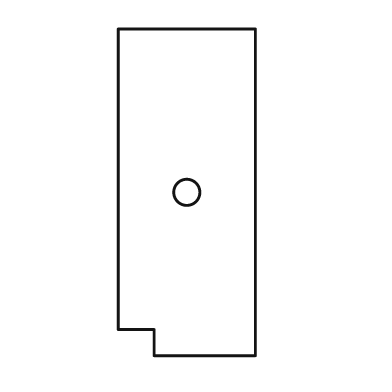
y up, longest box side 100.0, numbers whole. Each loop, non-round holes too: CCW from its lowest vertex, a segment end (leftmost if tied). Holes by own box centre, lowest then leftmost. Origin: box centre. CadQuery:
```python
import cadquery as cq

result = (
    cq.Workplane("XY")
    .moveTo(-10.0, -50.0)
    .lineTo(21.0, -50.0)
    .lineTo(21.0, 50.0)
    .lineTo(-21.0, 50.0)
    .lineTo(-21.0, -42.0)
    .lineTo(-10.0, -42.0)
    .close()
    .moveTo(0.0, 0.0)
    .circle(4.0)
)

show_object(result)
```